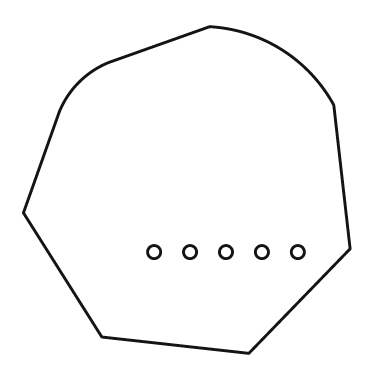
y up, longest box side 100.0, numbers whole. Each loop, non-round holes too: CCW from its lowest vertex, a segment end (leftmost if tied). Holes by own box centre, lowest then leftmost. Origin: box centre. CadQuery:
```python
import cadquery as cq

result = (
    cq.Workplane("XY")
    .moveTo(19.0, -50.0)
    .lineTo(50.0, -18.0)
    .lineTo(45.0, 26.0)
    .threePointArc((29.0, 43.0), (7.0, 50.0))
    .lineTo(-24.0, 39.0)
    .threePointArc((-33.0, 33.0), (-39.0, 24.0))
    .lineTo(-50.0, -7.0)
    .lineTo(-26.0, -45.0)
    .close()
    .moveTo(-10.0, -19.0)
    .circle(2.0)
    .moveTo(1.0, -19.0)
    .circle(2.0)
    .moveTo(12.0, -19.0)
    .circle(2.0)
    .moveTo(23.0, -19.0)
    .circle(2.0)
    .moveTo(34.0, -19.0)
    .circle(2.0)
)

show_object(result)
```